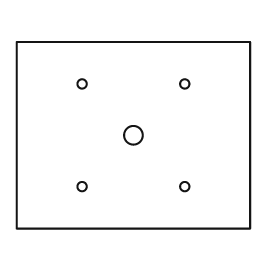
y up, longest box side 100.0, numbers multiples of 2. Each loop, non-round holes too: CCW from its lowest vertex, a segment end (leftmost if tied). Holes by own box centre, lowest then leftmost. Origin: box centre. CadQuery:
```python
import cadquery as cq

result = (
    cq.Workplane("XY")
    .moveTo(-50.0, -40.0)
    .lineTo(50.0, -40.0)
    .lineTo(50.0, 40.0)
    .lineTo(-50.0, 40.0)
    .close()
    .moveTo(-22.0, -22.0)
    .circle(2.0)
    .moveTo(22.0, -22.0)
    .circle(2.0)
    .moveTo(0.0, 0.0)
    .circle(4.0)
    .moveTo(-22.0, 22.0)
    .circle(2.0)
    .moveTo(22.0, 22.0)
    .circle(2.0)
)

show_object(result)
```